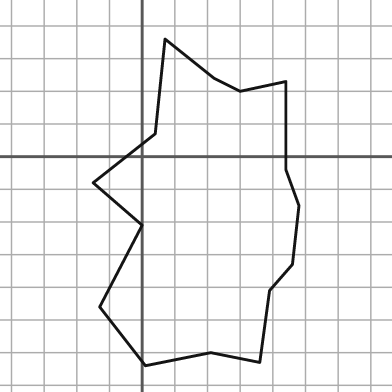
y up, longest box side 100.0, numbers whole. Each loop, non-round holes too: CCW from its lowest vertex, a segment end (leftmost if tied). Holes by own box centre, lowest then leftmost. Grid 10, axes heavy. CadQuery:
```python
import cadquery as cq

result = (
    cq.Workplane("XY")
    .moveTo(1.0, -64.0)
    .lineTo(21.0, -60.0)
    .lineTo(36.0, -63.0)
    .lineTo(39.0, -41.0)
    .lineTo(46.0, -33.0)
    .lineTo(48.0, -15.0)
    .lineTo(44.0, -4.0)
    .lineTo(44.0, 23.0)
    .lineTo(30.0, 20.0)
    .lineTo(22.0, 24.0)
    .lineTo(7.0, 36.0)
    .lineTo(4.0, 7.0)
    .lineTo(-15.0, -8.0)
    .lineTo(0.0, -21.0)
    .lineTo(-13.0, -46.0)
    .close()
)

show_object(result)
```